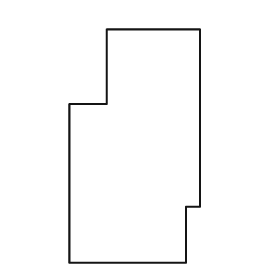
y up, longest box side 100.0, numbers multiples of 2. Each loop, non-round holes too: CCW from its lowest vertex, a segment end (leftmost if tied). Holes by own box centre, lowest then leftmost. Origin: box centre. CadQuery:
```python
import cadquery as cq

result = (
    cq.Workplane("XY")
    .moveTo(-28.0, -50.0)
    .lineTo(22.0, -50.0)
    .lineTo(22.0, -26.0)
    .lineTo(28.0, -26.0)
    .lineTo(28.0, 50.0)
    .lineTo(-12.0, 50.0)
    .lineTo(-12.0, 18.0)
    .lineTo(-28.0, 18.0)
    .close()
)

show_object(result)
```